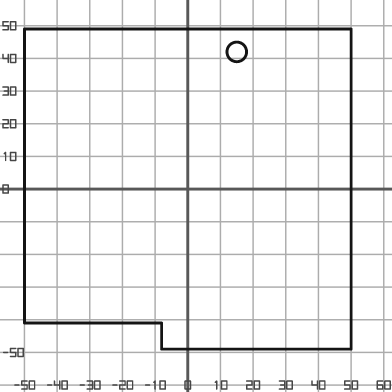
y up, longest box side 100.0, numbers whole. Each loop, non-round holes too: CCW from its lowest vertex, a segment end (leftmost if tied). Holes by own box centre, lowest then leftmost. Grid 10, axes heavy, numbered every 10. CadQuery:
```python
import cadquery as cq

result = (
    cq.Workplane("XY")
    .moveTo(-8.0, -49.0)
    .lineTo(50.0, -49.0)
    .lineTo(50.0, 49.0)
    .lineTo(-50.0, 49.0)
    .lineTo(-50.0, -41.0)
    .lineTo(-8.0, -41.0)
    .close()
    .moveTo(15.0, 42.0)
    .circle(3.0)
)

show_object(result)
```